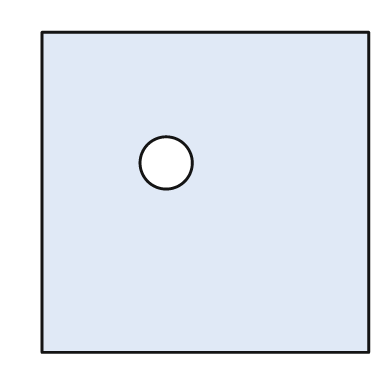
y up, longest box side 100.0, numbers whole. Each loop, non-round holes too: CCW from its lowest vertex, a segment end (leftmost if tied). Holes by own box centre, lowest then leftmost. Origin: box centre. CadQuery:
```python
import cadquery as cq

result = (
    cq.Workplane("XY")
    .moveTo(-50.0, -49.0)
    .lineTo(50.0, -49.0)
    .lineTo(50.0, 49.0)
    .lineTo(-50.0, 49.0)
    .close()
    .moveTo(-12.0, 9.0)
    .circle(8.0)
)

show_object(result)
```